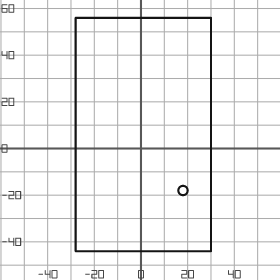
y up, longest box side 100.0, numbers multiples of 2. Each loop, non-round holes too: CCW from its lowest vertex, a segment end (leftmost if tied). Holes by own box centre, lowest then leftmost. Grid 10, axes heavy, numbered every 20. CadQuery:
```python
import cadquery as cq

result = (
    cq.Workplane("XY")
    .moveTo(-28.0, -44.0)
    .lineTo(30.0, -44.0)
    .lineTo(30.0, 56.0)
    .lineTo(-28.0, 56.0)
    .close()
    .moveTo(18.0, -18.0)
    .circle(2.0)
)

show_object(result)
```